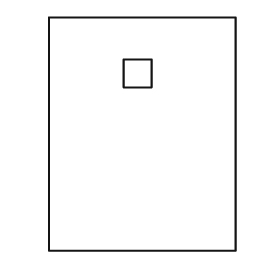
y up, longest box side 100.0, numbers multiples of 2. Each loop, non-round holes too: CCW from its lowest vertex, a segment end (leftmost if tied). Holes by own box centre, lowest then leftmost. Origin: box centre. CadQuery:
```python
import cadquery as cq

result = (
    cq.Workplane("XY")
    .moveTo(-40.0, -50.0)
    .lineTo(40.0, -50.0)
    .lineTo(40.0, 50.0)
    .lineTo(-40.0, 50.0)
    .close()
    .moveTo(-8.0, 20.0)
    .lineTo(4.0, 20.0)
    .lineTo(4.0, 32.0)
    .lineTo(-8.0, 32.0)
    .close()
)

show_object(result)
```